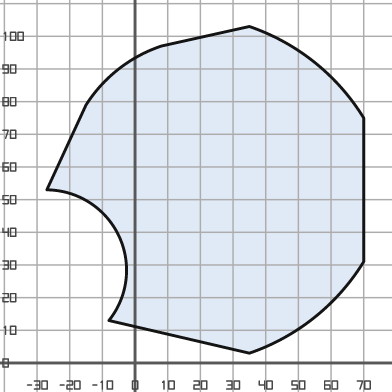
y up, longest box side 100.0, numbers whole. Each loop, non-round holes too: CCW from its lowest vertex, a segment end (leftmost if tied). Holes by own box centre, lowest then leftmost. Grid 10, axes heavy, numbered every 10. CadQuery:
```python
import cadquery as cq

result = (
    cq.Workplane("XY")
    .moveTo(35.0, 3.0)
    .threePointArc((55.0, 14.0), (70.0, 31.0))
    .lineTo(70.0, 75.0)
    .threePointArc((55.0, 92.0), (35.0, 103.0))
    .lineTo(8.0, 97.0)
    .threePointArc((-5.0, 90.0), (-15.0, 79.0))
    .lineTo(-27.0, 53.0)
    .threePointArc((-5.0, 39.0), (-8.0, 13.0))
    .close()
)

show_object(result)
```